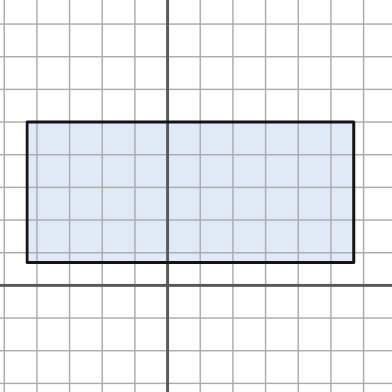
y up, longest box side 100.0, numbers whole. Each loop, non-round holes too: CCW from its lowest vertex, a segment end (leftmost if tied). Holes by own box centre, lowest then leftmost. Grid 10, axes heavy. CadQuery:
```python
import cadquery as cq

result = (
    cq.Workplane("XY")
    .moveTo(-43.0, 7.0)
    .lineTo(57.0, 7.0)
    .lineTo(57.0, 50.0)
    .lineTo(-43.0, 50.0)
    .close()
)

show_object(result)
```